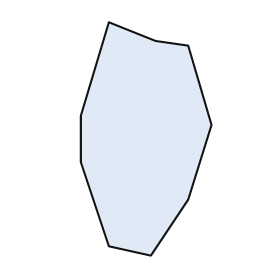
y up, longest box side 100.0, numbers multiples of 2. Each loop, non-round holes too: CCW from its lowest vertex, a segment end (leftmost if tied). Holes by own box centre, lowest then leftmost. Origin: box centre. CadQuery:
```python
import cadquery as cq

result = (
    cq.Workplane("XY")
    .moveTo(2.0, -50.0)
    .lineTo(18.0, -26.0)
    .lineTo(28.0, 6.0)
    .lineTo(18.0, 40.0)
    .lineTo(4.0, 42.0)
    .lineTo(-16.0, 50.0)
    .lineTo(-28.0, 10.0)
    .lineTo(-28.0, -10.0)
    .lineTo(-16.0, -46.0)
    .close()
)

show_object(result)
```